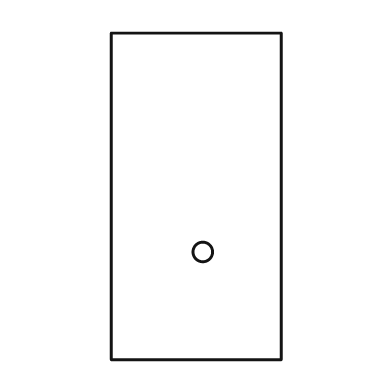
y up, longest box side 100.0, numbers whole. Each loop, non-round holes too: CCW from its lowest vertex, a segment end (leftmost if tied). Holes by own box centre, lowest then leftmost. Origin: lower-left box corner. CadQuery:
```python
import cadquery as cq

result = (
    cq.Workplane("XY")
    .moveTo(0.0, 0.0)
    .lineTo(52.0, 0.0)
    .lineTo(52.0, 100.0)
    .lineTo(0.0, 100.0)
    .close()
    .moveTo(28.0, 33.0)
    .circle(3.0)
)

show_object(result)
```